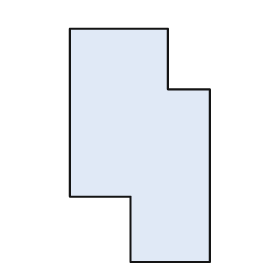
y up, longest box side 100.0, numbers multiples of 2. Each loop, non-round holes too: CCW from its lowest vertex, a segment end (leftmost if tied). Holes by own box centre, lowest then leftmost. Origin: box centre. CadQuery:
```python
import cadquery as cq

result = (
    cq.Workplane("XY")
    .moveTo(-4.0, -50.0)
    .lineTo(30.0, -50.0)
    .lineTo(30.0, 24.0)
    .lineTo(12.0, 24.0)
    .lineTo(12.0, 50.0)
    .lineTo(-30.0, 50.0)
    .lineTo(-30.0, -22.0)
    .lineTo(-4.0, -22.0)
    .close()
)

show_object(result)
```